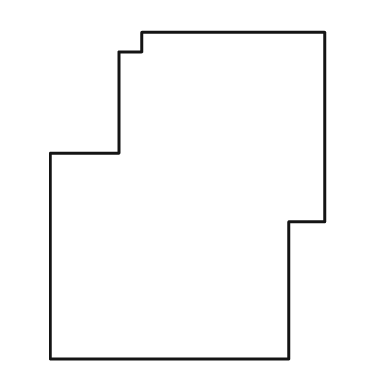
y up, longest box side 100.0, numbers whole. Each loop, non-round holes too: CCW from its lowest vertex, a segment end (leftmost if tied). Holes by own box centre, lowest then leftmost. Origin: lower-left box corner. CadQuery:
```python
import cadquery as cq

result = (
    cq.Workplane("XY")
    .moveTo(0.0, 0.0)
    .lineTo(73.0, 0.0)
    .lineTo(73.0, 42.0)
    .lineTo(84.0, 42.0)
    .lineTo(84.0, 100.0)
    .lineTo(28.0, 100.0)
    .lineTo(28.0, 94.0)
    .lineTo(21.0, 94.0)
    .lineTo(21.0, 63.0)
    .lineTo(0.0, 63.0)
    .close()
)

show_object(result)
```